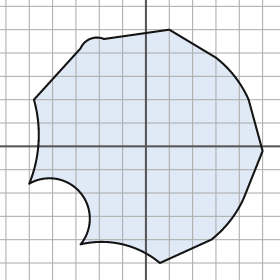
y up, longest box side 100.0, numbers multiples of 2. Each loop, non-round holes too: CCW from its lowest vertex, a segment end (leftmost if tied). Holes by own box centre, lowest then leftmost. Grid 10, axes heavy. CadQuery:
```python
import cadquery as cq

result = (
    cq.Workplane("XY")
    .moveTo(6.0, -50.0)
    .lineTo(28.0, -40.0)
    .threePointArc((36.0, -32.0), (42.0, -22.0))
    .lineTo(50.0, -2.0)
    .lineTo(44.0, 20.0)
    .threePointArc((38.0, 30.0), (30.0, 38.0))
    .lineTo(10.0, 50.0)
    .lineTo(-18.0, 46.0)
    .threePointArc((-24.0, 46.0), (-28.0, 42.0))
    .lineTo(-48.0, 20.0)
    .threePointArc((-46.0, 2.0), (-50.0, -16.0))
    .threePointArc((-28.0, -20.0), (-28.0, -42.0))
    .threePointArc((-10.0, -42.0), (6.0, -50.0))
    .close()
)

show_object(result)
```